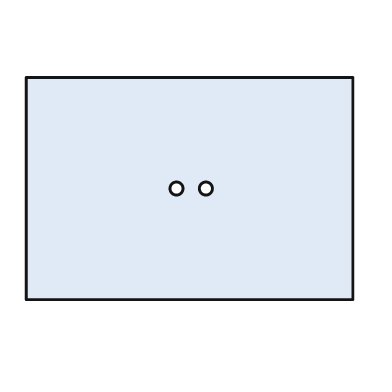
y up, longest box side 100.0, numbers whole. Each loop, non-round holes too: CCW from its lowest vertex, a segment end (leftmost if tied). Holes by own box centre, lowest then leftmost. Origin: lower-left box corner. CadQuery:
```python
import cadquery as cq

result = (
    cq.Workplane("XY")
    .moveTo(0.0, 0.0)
    .lineTo(100.0, 0.0)
    .lineTo(100.0, 68.0)
    .lineTo(0.0, 68.0)
    .close()
    .moveTo(46.0, 34.0)
    .circle(2.0)
    .moveTo(55.0, 34.0)
    .circle(2.0)
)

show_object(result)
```